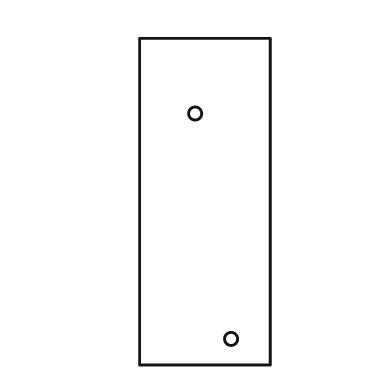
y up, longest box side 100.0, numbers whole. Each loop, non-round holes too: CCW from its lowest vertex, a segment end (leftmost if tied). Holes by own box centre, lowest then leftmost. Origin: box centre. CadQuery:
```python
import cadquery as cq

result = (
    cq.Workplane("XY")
    .moveTo(-20.0, -50.0)
    .lineTo(20.0, -50.0)
    .lineTo(20.0, 50.0)
    .lineTo(-20.0, 50.0)
    .close()
    .moveTo(8.0, -42.0)
    .circle(2.0)
    .moveTo(-3.0, 27.0)
    .circle(2.0)
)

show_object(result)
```